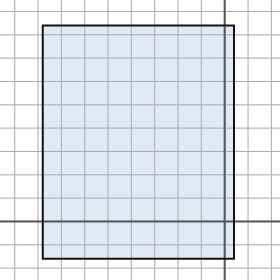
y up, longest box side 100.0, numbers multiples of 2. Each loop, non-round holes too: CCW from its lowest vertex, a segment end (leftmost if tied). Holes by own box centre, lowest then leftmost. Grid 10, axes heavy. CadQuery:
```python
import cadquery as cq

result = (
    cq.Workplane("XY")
    .moveTo(-78.0, -16.0)
    .lineTo(4.0, -16.0)
    .lineTo(4.0, 84.0)
    .lineTo(-78.0, 84.0)
    .close()
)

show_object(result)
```